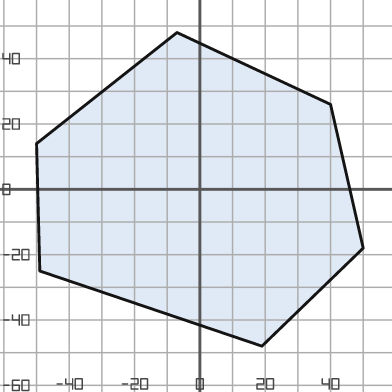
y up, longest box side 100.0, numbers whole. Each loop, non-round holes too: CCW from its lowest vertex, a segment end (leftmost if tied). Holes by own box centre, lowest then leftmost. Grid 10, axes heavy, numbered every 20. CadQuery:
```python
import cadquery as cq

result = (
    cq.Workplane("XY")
    .moveTo(19.0, -48.0)
    .lineTo(50.0, -18.0)
    .lineTo(40.0, 26.0)
    .lineTo(-7.0, 48.0)
    .lineTo(-50.0, 14.0)
    .lineTo(-49.0, -25.0)
    .close()
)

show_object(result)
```